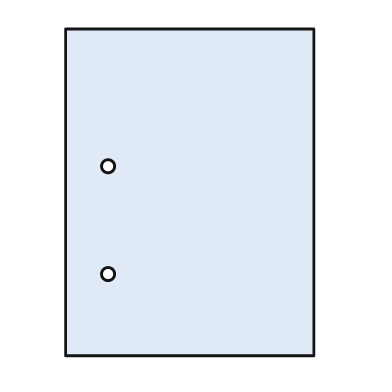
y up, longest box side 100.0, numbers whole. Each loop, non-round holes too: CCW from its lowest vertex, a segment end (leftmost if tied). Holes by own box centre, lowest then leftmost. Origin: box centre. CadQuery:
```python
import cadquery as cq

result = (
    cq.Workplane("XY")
    .moveTo(-38.0, -50.0)
    .lineTo(38.0, -50.0)
    .lineTo(38.0, 50.0)
    .lineTo(-38.0, 50.0)
    .close()
    .moveTo(-25.0, -25.0)
    .circle(2.0)
    .moveTo(-25.0, 8.0)
    .circle(2.0)
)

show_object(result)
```